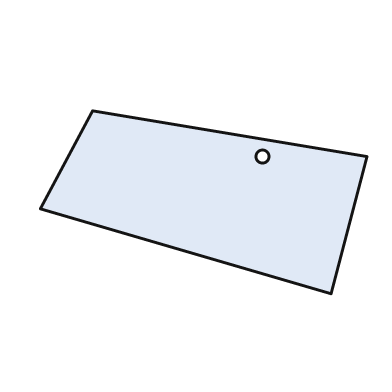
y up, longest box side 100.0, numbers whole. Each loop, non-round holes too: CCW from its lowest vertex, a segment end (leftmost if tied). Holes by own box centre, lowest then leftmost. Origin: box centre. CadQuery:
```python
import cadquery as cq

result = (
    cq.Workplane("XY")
    .moveTo(39.0, -28.0)
    .lineTo(50.0, 14.0)
    .lineTo(-34.0, 28.0)
    .lineTo(-50.0, -2.0)
    .close()
    .moveTo(18.0, 14.0)
    .circle(2.0)
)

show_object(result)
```